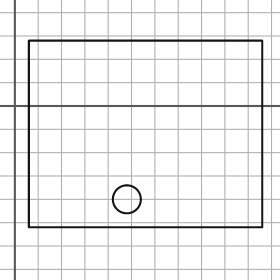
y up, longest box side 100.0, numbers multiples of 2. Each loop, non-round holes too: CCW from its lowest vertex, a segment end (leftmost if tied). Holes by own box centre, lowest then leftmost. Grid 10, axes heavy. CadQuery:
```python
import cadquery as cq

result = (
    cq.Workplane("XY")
    .moveTo(6.0, -52.0)
    .lineTo(106.0, -52.0)
    .lineTo(106.0, 28.0)
    .lineTo(6.0, 28.0)
    .close()
    .moveTo(48.0, -40.0)
    .circle(6.0)
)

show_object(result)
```